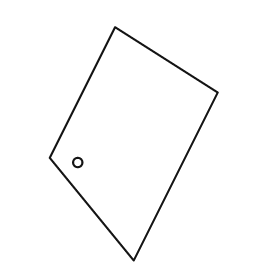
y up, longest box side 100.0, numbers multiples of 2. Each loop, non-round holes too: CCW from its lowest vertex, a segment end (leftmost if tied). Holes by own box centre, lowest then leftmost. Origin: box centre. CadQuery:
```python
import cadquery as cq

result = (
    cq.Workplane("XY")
    .moveTo(0.0, -50.0)
    .lineTo(36.0, 22.0)
    .lineTo(-8.0, 50.0)
    .lineTo(-36.0, -6.0)
    .close()
    .moveTo(-24.0, -8.0)
    .circle(2.0)
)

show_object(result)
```